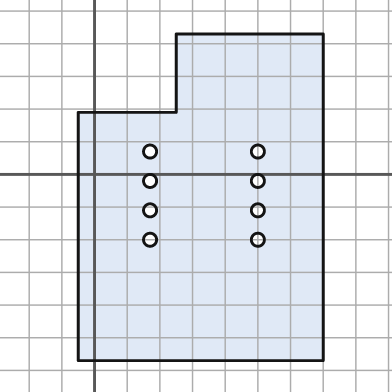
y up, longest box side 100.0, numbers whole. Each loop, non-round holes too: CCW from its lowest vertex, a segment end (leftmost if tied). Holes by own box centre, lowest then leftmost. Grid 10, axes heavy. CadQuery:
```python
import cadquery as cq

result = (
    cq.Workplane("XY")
    .moveTo(-5.0, -57.0)
    .lineTo(70.0, -57.0)
    .lineTo(70.0, 43.0)
    .lineTo(25.0, 43.0)
    .lineTo(25.0, 19.0)
    .lineTo(-5.0, 19.0)
    .close()
    .moveTo(17.0, -20.0)
    .circle(2.0)
    .moveTo(50.0, -20.0)
    .circle(2.0)
    .moveTo(17.0, -11.0)
    .circle(2.0)
    .moveTo(50.0, -11.0)
    .circle(2.0)
    .moveTo(17.0, -2.0)
    .circle(2.0)
    .moveTo(50.0, -2.0)
    .circle(2.0)
    .moveTo(17.0, 7.0)
    .circle(2.0)
    .moveTo(50.0, 7.0)
    .circle(2.0)
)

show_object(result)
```